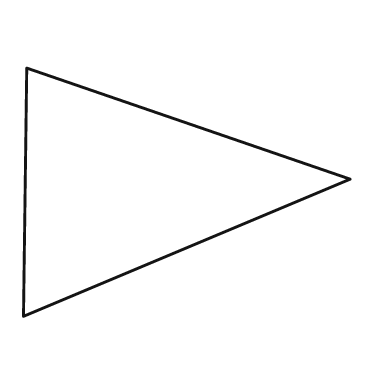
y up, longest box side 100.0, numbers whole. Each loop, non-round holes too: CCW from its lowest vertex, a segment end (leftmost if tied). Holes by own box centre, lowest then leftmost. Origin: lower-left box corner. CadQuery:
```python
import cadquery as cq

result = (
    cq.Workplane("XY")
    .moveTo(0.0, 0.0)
    .lineTo(100.0, 42.0)
    .lineTo(1.0, 76.0)
    .close()
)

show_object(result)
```